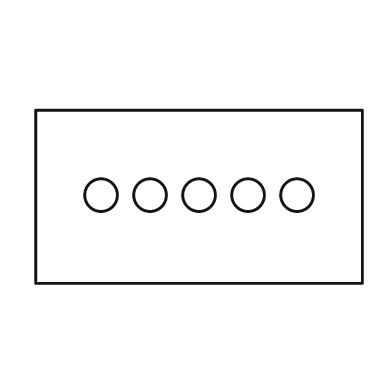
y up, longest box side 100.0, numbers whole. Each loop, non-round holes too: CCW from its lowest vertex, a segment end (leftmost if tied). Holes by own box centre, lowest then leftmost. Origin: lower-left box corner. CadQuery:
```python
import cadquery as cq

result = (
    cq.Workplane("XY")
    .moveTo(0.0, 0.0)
    .lineTo(100.0, 0.0)
    .lineTo(100.0, 53.0)
    .lineTo(0.0, 53.0)
    .close()
    .moveTo(20.0, 27.0)
    .circle(5.0)
    .moveTo(35.0, 27.0)
    .circle(5.0)
    .moveTo(50.0, 27.0)
    .circle(5.0)
    .moveTo(65.0, 27.0)
    .circle(5.0)
    .moveTo(80.0, 27.0)
    .circle(5.0)
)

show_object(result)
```